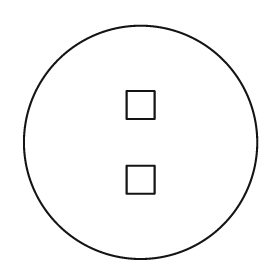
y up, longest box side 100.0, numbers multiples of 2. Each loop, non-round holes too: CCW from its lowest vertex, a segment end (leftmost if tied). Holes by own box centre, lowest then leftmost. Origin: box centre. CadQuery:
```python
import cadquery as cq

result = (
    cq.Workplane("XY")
    .moveTo(0.0, 0.0)
    .circle(50.0)
    .moveTo(-6.0, -22.0)
    .lineTo(6.0, -22.0)
    .lineTo(6.0, -10.0)
    .lineTo(-6.0, -10.0)
    .close()
    .moveTo(-6.0, 10.0)
    .lineTo(6.0, 10.0)
    .lineTo(6.0, 22.0)
    .lineTo(-6.0, 22.0)
    .close()
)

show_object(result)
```